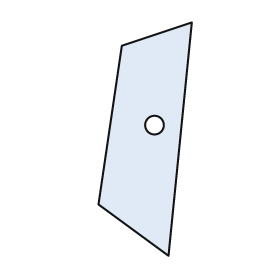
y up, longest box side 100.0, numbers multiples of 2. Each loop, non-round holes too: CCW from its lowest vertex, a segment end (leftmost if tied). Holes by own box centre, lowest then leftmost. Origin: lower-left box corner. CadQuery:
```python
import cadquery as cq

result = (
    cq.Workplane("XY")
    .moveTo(30.0, 0.0)
    .lineTo(40.0, 100.0)
    .lineTo(10.0, 90.0)
    .lineTo(0.0, 22.0)
    .close()
    .moveTo(24.0, 56.0)
    .circle(4.0)
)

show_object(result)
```